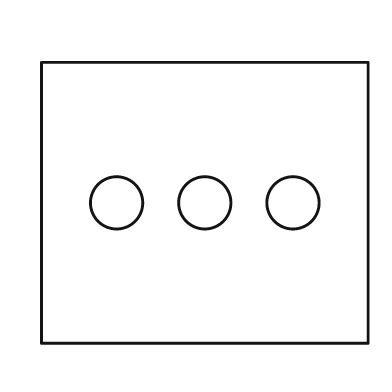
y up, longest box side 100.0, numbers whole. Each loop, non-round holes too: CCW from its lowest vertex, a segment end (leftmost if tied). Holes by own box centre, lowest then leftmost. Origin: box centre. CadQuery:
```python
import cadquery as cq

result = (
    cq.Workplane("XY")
    .moveTo(-50.0, -43.0)
    .lineTo(50.0, -43.0)
    .lineTo(50.0, 43.0)
    .lineTo(-50.0, 43.0)
    .close()
    .moveTo(-27.0, 0.0)
    .circle(8.0)
    .moveTo(0.0, 0.0)
    .circle(8.0)
    .moveTo(27.0, 0.0)
    .circle(8.0)
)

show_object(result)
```